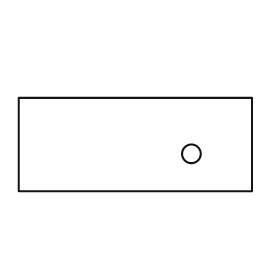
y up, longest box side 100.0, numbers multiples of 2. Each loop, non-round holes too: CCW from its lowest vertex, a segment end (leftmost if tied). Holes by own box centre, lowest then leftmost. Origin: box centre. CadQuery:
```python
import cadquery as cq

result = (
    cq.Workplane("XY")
    .moveTo(-50.0, -20.0)
    .lineTo(50.0, -20.0)
    .lineTo(50.0, 20.0)
    .lineTo(-50.0, 20.0)
    .close()
    .moveTo(24.0, -4.0)
    .circle(4.0)
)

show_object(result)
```